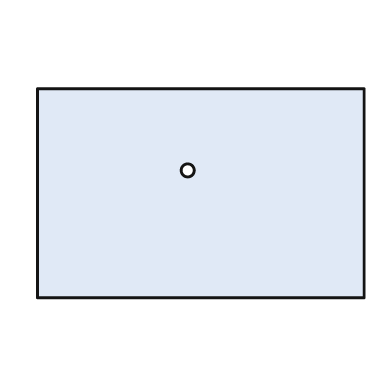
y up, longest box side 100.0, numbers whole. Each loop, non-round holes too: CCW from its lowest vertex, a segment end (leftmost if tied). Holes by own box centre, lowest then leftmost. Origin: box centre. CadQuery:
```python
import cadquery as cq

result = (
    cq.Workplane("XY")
    .moveTo(-50.0, -32.0)
    .lineTo(50.0, -32.0)
    .lineTo(50.0, 32.0)
    .lineTo(-50.0, 32.0)
    .close()
    .moveTo(-4.0, 7.0)
    .circle(2.0)
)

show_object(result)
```